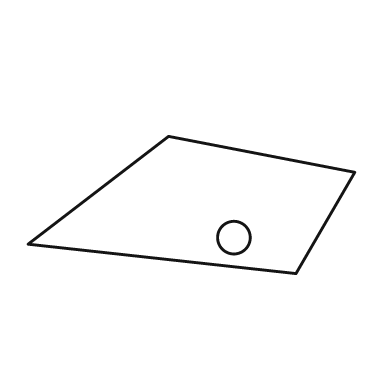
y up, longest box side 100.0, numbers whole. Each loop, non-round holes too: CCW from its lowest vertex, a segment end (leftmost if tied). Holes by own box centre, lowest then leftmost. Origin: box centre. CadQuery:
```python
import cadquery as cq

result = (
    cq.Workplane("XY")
    .moveTo(32.0, -21.0)
    .lineTo(50.0, 10.0)
    .lineTo(-7.0, 21.0)
    .lineTo(-50.0, -12.0)
    .close()
    .moveTo(13.0, -10.0)
    .circle(5.0)
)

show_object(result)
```